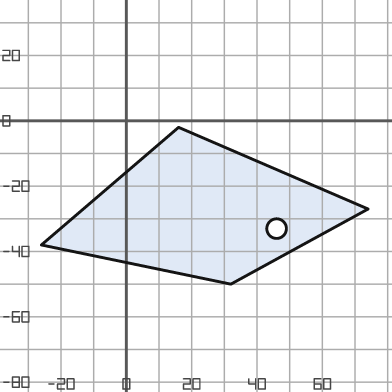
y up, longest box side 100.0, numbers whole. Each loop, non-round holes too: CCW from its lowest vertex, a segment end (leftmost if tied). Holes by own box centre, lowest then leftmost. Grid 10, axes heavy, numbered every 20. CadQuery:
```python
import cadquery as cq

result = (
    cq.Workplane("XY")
    .moveTo(32.0, -50.0)
    .lineTo(74.0, -27.0)
    .lineTo(16.0, -2.0)
    .lineTo(-26.0, -38.0)
    .close()
    .moveTo(46.0, -33.0)
    .circle(3.0)
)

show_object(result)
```